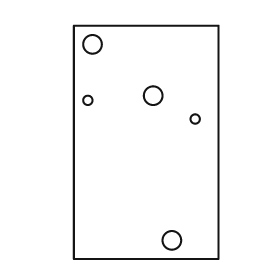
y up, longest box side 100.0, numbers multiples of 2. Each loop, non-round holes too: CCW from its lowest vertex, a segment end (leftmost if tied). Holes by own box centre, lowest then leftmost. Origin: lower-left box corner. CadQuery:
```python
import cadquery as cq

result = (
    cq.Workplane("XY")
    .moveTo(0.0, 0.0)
    .lineTo(62.0, 0.0)
    .lineTo(62.0, 100.0)
    .lineTo(0.0, 100.0)
    .close()
    .moveTo(42.0, 8.0)
    .circle(4.0)
    .moveTo(52.0, 60.0)
    .circle(2.0)
    .moveTo(6.0, 68.0)
    .circle(2.0)
    .moveTo(34.0, 70.0)
    .circle(4.0)
    .moveTo(8.0, 92.0)
    .circle(4.0)
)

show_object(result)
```